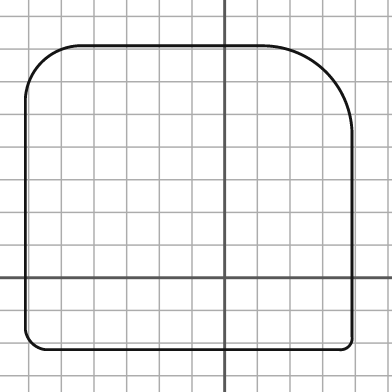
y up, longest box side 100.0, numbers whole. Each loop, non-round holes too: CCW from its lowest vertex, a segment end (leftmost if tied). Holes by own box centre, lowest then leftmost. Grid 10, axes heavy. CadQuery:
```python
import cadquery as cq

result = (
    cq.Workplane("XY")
    .moveTo(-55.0, -22.0)
    .lineTo(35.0, -22.0)
    .threePointArc((38.0, -21.0), (39.0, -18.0))
    .lineTo(39.0, 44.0)
    .threePointArc((31.0, 63.0), (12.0, 71.0))
    .lineTo(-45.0, 71.0)
    .threePointArc((-56.0, 66.0), (-61.0, 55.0))
    .lineTo(-61.0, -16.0)
    .threePointArc((-59.0, -20.0), (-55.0, -22.0))
    .close()
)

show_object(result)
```